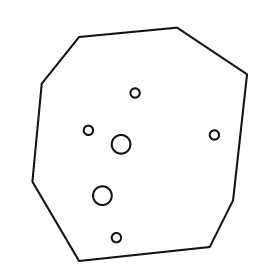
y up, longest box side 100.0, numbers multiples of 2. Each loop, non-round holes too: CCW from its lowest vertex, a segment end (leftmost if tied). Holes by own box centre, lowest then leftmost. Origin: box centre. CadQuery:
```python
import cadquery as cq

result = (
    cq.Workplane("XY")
    .moveTo(-26.0, -50.0)
    .lineTo(30.0, -44.0)
    .lineTo(40.0, -24.0)
    .lineTo(46.0, 30.0)
    .lineTo(16.0, 50.0)
    .lineTo(-26.0, 46.0)
    .lineTo(-42.0, 26.0)
    .lineTo(-46.0, -16.0)
    .close()
    .moveTo(-10.0, -40.0)
    .circle(2.0)
    .moveTo(-16.0, -22.0)
    .circle(4.0)
    .moveTo(-8.0, 0.0)
    .circle(4.0)
    .moveTo(32.0, 4.0)
    .circle(2.0)
    .moveTo(-22.0, 6.0)
    .circle(2.0)
    .moveTo(-2.0, 22.0)
    .circle(2.0)
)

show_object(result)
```